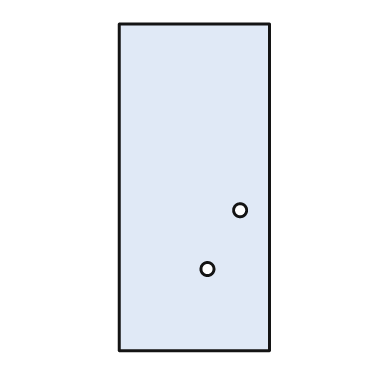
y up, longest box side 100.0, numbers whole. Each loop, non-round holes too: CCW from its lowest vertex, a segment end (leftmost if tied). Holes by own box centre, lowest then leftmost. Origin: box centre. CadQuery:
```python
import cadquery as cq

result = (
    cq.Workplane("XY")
    .moveTo(-23.0, -50.0)
    .lineTo(23.0, -50.0)
    .lineTo(23.0, 50.0)
    .lineTo(-23.0, 50.0)
    .close()
    .moveTo(4.0, -25.0)
    .circle(2.0)
    .moveTo(14.0, -7.0)
    .circle(2.0)
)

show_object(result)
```